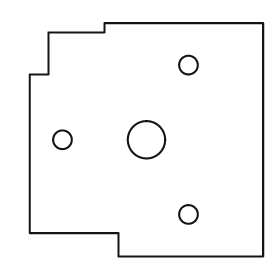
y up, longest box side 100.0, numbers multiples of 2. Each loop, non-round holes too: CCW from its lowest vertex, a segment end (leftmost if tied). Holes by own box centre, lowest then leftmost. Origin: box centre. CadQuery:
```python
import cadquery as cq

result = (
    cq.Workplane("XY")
    .moveTo(-12.0, -50.0)
    .lineTo(50.0, -50.0)
    .lineTo(50.0, 50.0)
    .lineTo(-18.0, 50.0)
    .lineTo(-18.0, 46.0)
    .lineTo(-42.0, 46.0)
    .lineTo(-42.0, 28.0)
    .lineTo(-50.0, 28.0)
    .lineTo(-50.0, -40.0)
    .lineTo(-12.0, -40.0)
    .close()
    .moveTo(18.0, -32.0)
    .circle(4.0)
    .moveTo(-36.0, 0.0)
    .circle(4.0)
    .moveTo(0.0, 0.0)
    .circle(8.0)
    .moveTo(18.0, 32.0)
    .circle(4.0)
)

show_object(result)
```